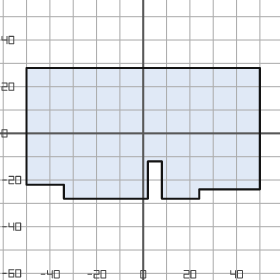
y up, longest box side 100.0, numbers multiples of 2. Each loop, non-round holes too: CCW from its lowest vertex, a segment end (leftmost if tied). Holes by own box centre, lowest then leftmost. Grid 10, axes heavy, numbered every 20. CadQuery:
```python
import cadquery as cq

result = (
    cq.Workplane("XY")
    .moveTo(-34.0, -28.0)
    .lineTo(2.0, -28.0)
    .lineTo(2.0, -12.0)
    .lineTo(8.0, -12.0)
    .lineTo(8.0, -28.0)
    .lineTo(24.0, -28.0)
    .lineTo(24.0, -24.0)
    .lineTo(50.0, -24.0)
    .lineTo(50.0, 28.0)
    .lineTo(-50.0, 28.0)
    .lineTo(-50.0, -22.0)
    .lineTo(-34.0, -22.0)
    .close()
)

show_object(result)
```